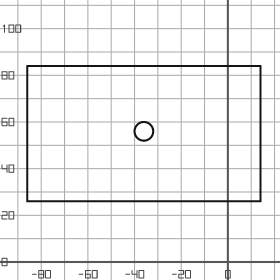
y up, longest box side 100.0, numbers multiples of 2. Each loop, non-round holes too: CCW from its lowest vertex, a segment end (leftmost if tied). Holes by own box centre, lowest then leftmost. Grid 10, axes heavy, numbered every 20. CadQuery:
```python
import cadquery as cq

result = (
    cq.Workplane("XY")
    .moveTo(-86.0, 26.0)
    .lineTo(14.0, 26.0)
    .lineTo(14.0, 84.0)
    .lineTo(-86.0, 84.0)
    .close()
    .moveTo(-36.0, 56.0)
    .circle(4.0)
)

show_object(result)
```